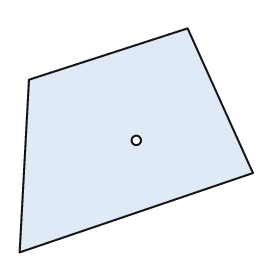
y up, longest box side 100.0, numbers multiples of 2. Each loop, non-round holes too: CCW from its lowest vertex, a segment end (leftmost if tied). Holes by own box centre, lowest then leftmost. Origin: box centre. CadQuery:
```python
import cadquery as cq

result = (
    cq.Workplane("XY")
    .moveTo(-50.0, -48.0)
    .lineTo(50.0, -14.0)
    .lineTo(22.0, 48.0)
    .lineTo(-46.0, 26.0)
    .close()
    .moveTo(0.0, 0.0)
    .circle(2.0)
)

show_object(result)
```